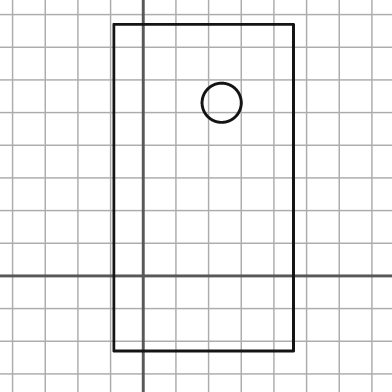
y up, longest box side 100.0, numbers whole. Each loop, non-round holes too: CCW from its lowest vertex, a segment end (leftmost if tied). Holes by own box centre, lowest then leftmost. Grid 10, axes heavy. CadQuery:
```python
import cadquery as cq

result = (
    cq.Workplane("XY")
    .moveTo(-9.0, -23.0)
    .lineTo(46.0, -23.0)
    .lineTo(46.0, 77.0)
    .lineTo(-9.0, 77.0)
    .close()
    .moveTo(24.0, 53.0)
    .circle(6.0)
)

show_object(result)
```